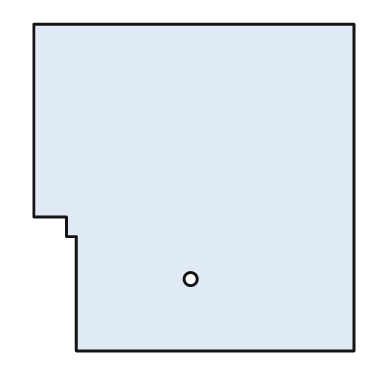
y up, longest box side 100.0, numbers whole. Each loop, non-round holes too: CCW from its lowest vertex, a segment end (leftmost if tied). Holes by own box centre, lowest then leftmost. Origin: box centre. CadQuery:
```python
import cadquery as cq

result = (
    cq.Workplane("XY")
    .moveTo(-36.0, -50.0)
    .lineTo(49.0, -50.0)
    .lineTo(49.0, 50.0)
    .lineTo(-49.0, 50.0)
    .lineTo(-49.0, -9.0)
    .lineTo(-39.0, -9.0)
    .lineTo(-39.0, -15.0)
    .lineTo(-36.0, -15.0)
    .close()
    .moveTo(-1.0, -28.0)
    .circle(2.0)
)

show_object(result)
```